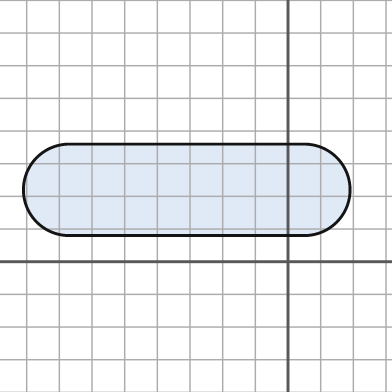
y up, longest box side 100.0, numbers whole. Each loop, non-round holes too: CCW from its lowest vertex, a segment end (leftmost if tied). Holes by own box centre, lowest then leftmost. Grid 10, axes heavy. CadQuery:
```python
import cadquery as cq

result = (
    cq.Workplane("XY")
    .moveTo(-67.0, 8.0)
    .lineTo(5.0, 8.0)
    .threePointArc((19.0, 22.0), (5.0, 36.0))
    .lineTo(-67.0, 36.0)
    .threePointArc((-81.0, 22.0), (-67.0, 8.0))
    .close()
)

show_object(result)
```